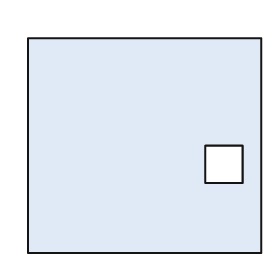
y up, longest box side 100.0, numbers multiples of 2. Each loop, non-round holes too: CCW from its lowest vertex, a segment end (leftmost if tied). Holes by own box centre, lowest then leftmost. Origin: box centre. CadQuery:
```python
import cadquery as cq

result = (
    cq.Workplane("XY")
    .moveTo(-50.0, -46.0)
    .lineTo(50.0, -46.0)
    .lineTo(50.0, 46.0)
    .lineTo(-50.0, 46.0)
    .close()
    .moveTo(26.0, -16.0)
    .lineTo(42.0, -16.0)
    .lineTo(42.0, 0.0)
    .lineTo(26.0, 0.0)
    .close()
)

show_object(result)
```